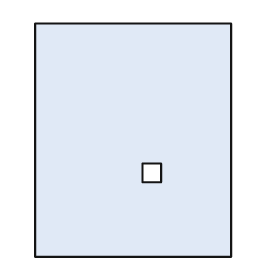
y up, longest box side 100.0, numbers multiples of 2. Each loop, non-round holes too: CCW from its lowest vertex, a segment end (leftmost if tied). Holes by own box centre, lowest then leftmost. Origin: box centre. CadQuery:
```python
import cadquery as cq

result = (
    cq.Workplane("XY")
    .moveTo(-42.0, -50.0)
    .lineTo(42.0, -50.0)
    .lineTo(42.0, 50.0)
    .lineTo(-42.0, 50.0)
    .close()
    .moveTo(4.0, -18.0)
    .lineTo(12.0, -18.0)
    .lineTo(12.0, -10.0)
    .lineTo(4.0, -10.0)
    .close()
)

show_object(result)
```